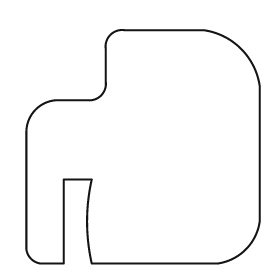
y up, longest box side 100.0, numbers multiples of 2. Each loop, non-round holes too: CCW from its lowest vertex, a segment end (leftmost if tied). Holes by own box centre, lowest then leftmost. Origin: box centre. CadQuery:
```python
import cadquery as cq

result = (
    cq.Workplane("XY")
    .moveTo(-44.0, -50.0)
    .lineTo(-34.0, -50.0)
    .lineTo(-34.0, -14.0)
    .lineTo(-22.0, -14.0)
    .threePointArc((-24.0, -32.0), (-22.0, -50.0))
    .lineTo(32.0, -50.0)
    .threePointArc((44.0, -44.0), (50.0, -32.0))
    .lineTo(50.0, 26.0)
    .threePointArc((42.0, 42.0), (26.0, 50.0))
    .lineTo(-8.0, 50.0)
    .threePointArc((-14.0, 48.0), (-16.0, 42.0))
    .lineTo(-16.0, 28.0)
    .threePointArc((-18.0, 22.0), (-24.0, 20.0))
    .lineTo(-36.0, 20.0)
    .threePointArc((-46.0, 16.0), (-50.0, 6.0))
    .lineTo(-50.0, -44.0)
    .threePointArc((-48.0, -48.0), (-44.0, -50.0))
    .close()
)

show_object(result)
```